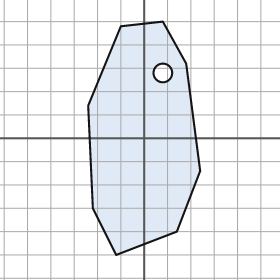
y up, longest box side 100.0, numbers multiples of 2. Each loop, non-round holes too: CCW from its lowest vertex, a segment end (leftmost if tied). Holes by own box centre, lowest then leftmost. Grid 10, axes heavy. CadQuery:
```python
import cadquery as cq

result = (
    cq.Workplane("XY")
    .moveTo(-12.0, -50.0)
    .lineTo(14.0, -40.0)
    .lineTo(24.0, -14.0)
    .lineTo(18.0, 32.0)
    .lineTo(8.0, 50.0)
    .lineTo(-10.0, 48.0)
    .lineTo(-24.0, 14.0)
    .lineTo(-22.0, -30.0)
    .close()
    .moveTo(8.0, 28.0)
    .circle(4.0)
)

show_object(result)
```